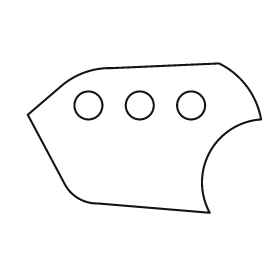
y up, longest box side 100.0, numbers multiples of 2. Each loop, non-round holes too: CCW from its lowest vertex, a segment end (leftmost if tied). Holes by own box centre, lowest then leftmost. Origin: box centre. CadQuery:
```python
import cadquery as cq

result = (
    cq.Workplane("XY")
    .moveTo(28.0, -32.0)
    .threePointArc((28.0, -6.0), (50.0, 8.0))
    .threePointArc((44.0, 22.0), (32.0, 32.0))
    .lineTo(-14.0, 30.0)
    .threePointArc((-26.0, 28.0), (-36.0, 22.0))
    .lineTo(-50.0, 10.0)
    .lineTo(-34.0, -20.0)
    .threePointArc((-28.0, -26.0), (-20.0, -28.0))
    .close()
    .moveTo(-24.0, 14.0)
    .circle(6.0)
    .moveTo(-2.0, 14.0)
    .circle(6.0)
    .moveTo(20.0, 14.0)
    .circle(6.0)
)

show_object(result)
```